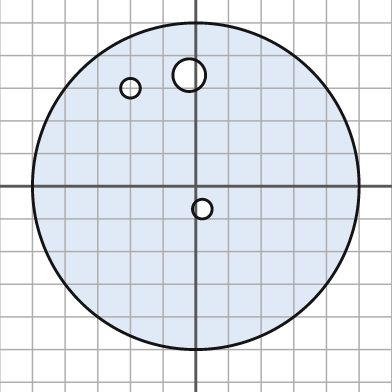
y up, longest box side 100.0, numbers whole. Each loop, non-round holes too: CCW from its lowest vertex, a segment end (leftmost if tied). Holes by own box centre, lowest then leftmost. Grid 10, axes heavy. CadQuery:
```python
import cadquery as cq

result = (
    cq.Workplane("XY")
    .moveTo(0.0, 0.0)
    .circle(50.0)
    .moveTo(2.0, -7.0)
    .circle(3.0)
    .moveTo(-20.0, 30.0)
    .circle(3.0)
    .moveTo(-2.0, 34.0)
    .circle(5.0)
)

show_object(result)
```